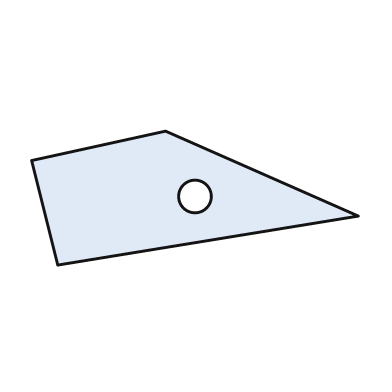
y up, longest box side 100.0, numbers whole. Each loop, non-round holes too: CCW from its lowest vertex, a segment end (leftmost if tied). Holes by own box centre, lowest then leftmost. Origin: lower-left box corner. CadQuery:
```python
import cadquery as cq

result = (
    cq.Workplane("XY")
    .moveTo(8.0, 0.0)
    .lineTo(100.0, 15.0)
    .lineTo(41.0, 41.0)
    .lineTo(0.0, 32.0)
    .close()
    .moveTo(50.0, 21.0)
    .circle(5.0)
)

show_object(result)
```